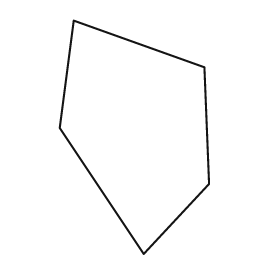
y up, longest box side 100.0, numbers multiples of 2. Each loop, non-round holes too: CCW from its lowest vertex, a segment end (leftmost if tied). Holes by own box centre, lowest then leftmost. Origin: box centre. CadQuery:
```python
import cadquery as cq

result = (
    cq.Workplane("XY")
    .moveTo(4.0, -50.0)
    .lineTo(32.0, -20.0)
    .lineTo(30.0, 30.0)
    .lineTo(-26.0, 50.0)
    .lineTo(-32.0, 4.0)
    .close()
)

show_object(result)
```